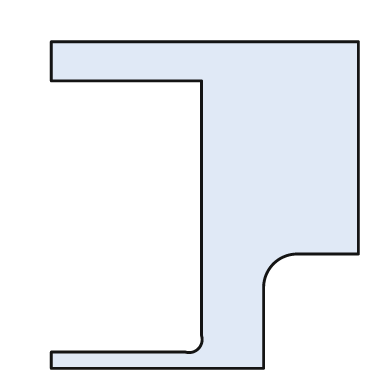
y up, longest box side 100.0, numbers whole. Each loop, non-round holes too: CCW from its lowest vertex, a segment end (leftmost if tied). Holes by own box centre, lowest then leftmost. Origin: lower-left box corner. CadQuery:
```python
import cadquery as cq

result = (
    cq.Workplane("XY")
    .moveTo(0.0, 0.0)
    .lineTo(65.0, 0.0)
    .lineTo(65.0, 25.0)
    .threePointArc((68.0, 32.0), (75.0, 35.0))
    .lineTo(94.0, 35.0)
    .lineTo(94.0, 100.0)
    .lineTo(0.0, 100.0)
    .lineTo(0.0, 88.0)
    .lineTo(46.0, 88.0)
    .lineTo(46.0, 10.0)
    .threePointArc((45.0, 6.0), (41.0, 5.0))
    .lineTo(0.0, 5.0)
    .close()
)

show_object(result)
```